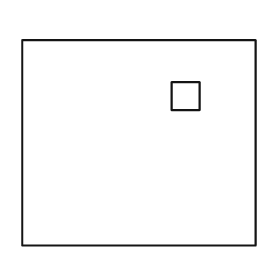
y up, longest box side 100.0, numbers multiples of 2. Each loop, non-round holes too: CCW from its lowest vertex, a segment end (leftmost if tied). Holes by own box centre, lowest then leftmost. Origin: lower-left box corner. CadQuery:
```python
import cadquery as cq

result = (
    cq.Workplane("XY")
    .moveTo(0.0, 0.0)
    .lineTo(100.0, 0.0)
    .lineTo(100.0, 88.0)
    .lineTo(0.0, 88.0)
    .close()
    .moveTo(64.0, 58.0)
    .lineTo(76.0, 58.0)
    .lineTo(76.0, 70.0)
    .lineTo(64.0, 70.0)
    .close()
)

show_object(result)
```